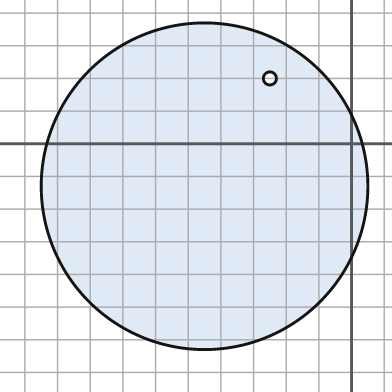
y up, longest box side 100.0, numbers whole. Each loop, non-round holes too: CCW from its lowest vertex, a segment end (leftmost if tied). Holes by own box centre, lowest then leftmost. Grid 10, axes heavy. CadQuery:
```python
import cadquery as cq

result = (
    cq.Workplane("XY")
    .moveTo(-45.0, -13.0)
    .circle(50.0)
    .moveTo(-25.0, 20.0)
    .circle(2.0)
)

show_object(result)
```